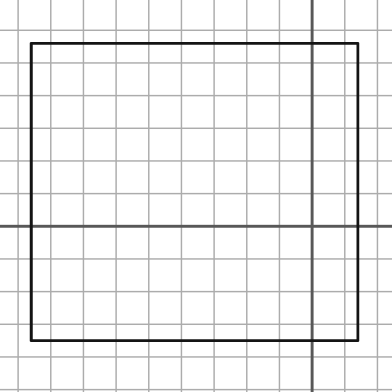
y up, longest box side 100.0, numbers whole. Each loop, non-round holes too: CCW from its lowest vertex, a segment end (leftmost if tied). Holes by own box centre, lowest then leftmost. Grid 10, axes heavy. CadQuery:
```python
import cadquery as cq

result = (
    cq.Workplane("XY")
    .moveTo(-86.0, -35.0)
    .lineTo(14.0, -35.0)
    .lineTo(14.0, 56.0)
    .lineTo(-86.0, 56.0)
    .close()
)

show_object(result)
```